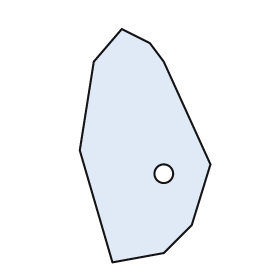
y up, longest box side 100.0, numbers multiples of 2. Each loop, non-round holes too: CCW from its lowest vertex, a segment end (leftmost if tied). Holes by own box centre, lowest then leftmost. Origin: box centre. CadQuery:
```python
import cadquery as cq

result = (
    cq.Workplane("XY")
    .moveTo(-14.0, -50.0)
    .lineTo(8.0, -46.0)
    .lineTo(20.0, -34.0)
    .lineTo(28.0, -8.0)
    .lineTo(8.0, 36.0)
    .lineTo(2.0, 44.0)
    .lineTo(-10.0, 50.0)
    .lineTo(-22.0, 36.0)
    .lineTo(-28.0, -2.0)
    .close()
    .moveTo(8.0, -12.0)
    .circle(4.0)
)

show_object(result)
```